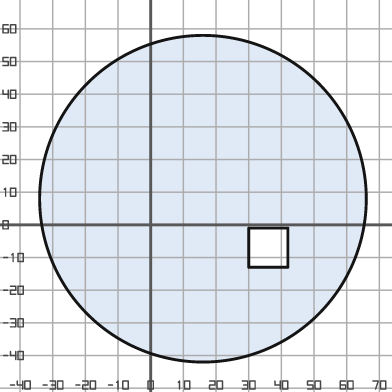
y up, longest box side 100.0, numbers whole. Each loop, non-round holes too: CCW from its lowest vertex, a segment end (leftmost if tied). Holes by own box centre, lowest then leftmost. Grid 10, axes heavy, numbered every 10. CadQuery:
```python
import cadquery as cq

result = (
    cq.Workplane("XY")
    .moveTo(16.0, 8.0)
    .circle(50.0)
    .moveTo(30.0, -13.0)
    .lineTo(42.0, -13.0)
    .lineTo(42.0, -1.0)
    .lineTo(30.0, -1.0)
    .close()
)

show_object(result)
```